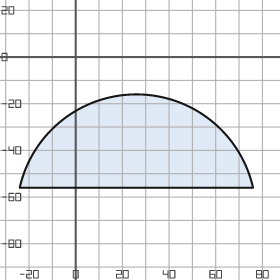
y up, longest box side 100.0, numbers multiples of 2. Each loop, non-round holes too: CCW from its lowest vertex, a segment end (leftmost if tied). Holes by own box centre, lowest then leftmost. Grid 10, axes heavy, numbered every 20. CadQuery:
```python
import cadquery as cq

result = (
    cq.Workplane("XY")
    .moveTo(-24.0, -56.0)
    .lineTo(76.0, -56.0)
    .threePointArc((26.0, -16.0), (-24.0, -56.0))
    .close()
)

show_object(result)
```